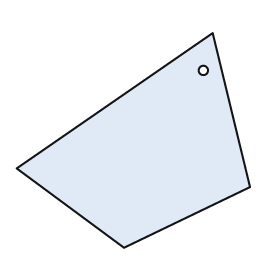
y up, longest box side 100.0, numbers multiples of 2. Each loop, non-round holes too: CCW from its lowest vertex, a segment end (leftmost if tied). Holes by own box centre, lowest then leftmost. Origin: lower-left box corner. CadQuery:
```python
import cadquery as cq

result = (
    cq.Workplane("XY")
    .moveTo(46.0, 0.0)
    .lineTo(100.0, 26.0)
    .lineTo(84.0, 92.0)
    .lineTo(0.0, 34.0)
    .close()
    .moveTo(80.0, 76.0)
    .circle(2.0)
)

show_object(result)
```